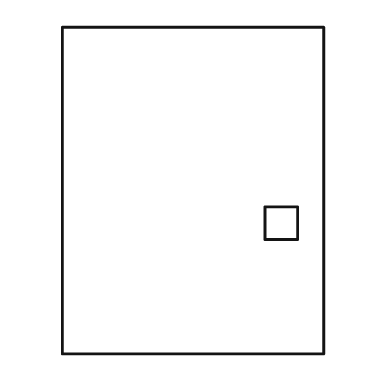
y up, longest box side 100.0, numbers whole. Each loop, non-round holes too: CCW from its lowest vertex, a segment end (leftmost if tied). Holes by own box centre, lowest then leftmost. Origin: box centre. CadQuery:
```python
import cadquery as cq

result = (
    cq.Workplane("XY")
    .moveTo(-40.0, -50.0)
    .lineTo(40.0, -50.0)
    .lineTo(40.0, 50.0)
    .lineTo(-40.0, 50.0)
    .close()
    .moveTo(22.0, -15.0)
    .lineTo(32.0, -15.0)
    .lineTo(32.0, -5.0)
    .lineTo(22.0, -5.0)
    .close()
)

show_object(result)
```